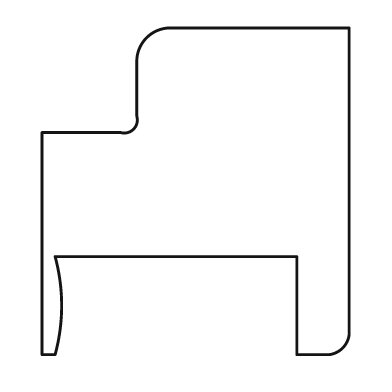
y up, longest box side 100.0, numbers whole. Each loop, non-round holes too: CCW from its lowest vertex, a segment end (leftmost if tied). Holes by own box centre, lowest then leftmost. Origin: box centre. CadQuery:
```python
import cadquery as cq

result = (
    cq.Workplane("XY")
    .moveTo(-47.0, -50.0)
    .lineTo(-43.0, -50.0)
    .threePointArc((-41.0, -35.0), (-43.0, -20.0))
    .lineTo(31.0, -20.0)
    .lineTo(31.0, -50.0)
    .lineTo(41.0, -50.0)
    .threePointArc((45.0, -48.0), (47.0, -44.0))
    .lineTo(47.0, 50.0)
    .lineTo(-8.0, 50.0)
    .threePointArc((-15.0, 47.0), (-18.0, 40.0))
    .lineTo(-18.0, 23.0)
    .threePointArc((-19.0, 19.0), (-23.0, 18.0))
    .lineTo(-47.0, 18.0)
    .close()
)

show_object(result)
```